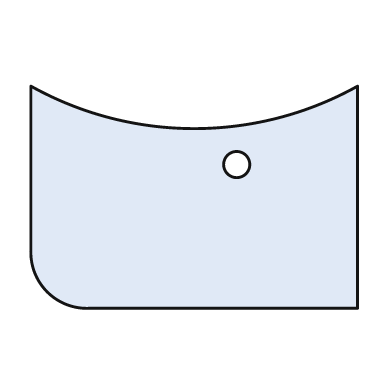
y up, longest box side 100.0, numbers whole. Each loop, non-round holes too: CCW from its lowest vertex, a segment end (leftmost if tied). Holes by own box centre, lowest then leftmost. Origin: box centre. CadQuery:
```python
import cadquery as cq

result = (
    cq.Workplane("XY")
    .moveTo(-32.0, -34.0)
    .lineTo(50.0, -34.0)
    .lineTo(50.0, 34.0)
    .threePointArc((0.0, 21.0), (-50.0, 34.0))
    .lineTo(-50.0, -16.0)
    .threePointArc((-45.0, -29.0), (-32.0, -34.0))
    .close()
    .moveTo(13.0, 10.0)
    .circle(4.0)
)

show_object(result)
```